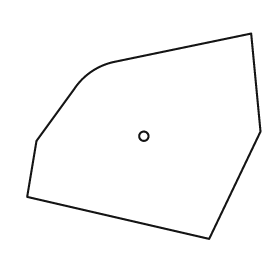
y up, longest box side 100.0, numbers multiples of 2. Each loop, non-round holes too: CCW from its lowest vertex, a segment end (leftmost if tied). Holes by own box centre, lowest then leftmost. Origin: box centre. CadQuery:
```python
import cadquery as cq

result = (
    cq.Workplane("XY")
    .moveTo(28.0, -44.0)
    .lineTo(50.0, 2.0)
    .lineTo(46.0, 44.0)
    .lineTo(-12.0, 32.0)
    .threePointArc((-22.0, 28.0), (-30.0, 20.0))
    .lineTo(-46.0, -2.0)
    .lineTo(-50.0, -26.0)
    .close()
    .moveTo(0.0, 0.0)
    .circle(2.0)
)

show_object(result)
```